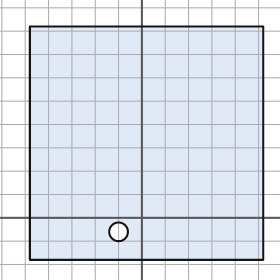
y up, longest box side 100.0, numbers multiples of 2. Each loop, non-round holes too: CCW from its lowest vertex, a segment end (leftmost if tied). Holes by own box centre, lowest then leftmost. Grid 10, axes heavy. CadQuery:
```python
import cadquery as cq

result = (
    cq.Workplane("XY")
    .moveTo(-48.0, -18.0)
    .lineTo(52.0, -18.0)
    .lineTo(52.0, 82.0)
    .lineTo(-48.0, 82.0)
    .close()
    .moveTo(-10.0, -6.0)
    .circle(4.0)
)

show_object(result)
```